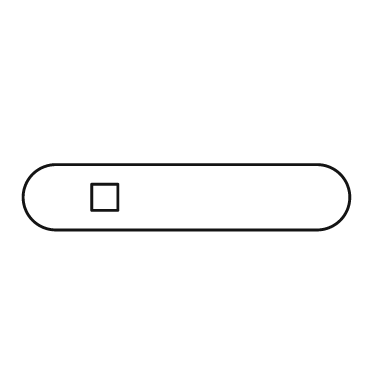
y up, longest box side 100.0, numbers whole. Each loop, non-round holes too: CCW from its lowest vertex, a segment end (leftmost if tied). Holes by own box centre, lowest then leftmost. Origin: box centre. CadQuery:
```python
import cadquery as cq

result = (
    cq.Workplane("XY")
    .moveTo(-40.0, -10.0)
    .lineTo(40.0, -10.0)
    .threePointArc((50.0, 0.0), (40.0, 10.0))
    .lineTo(-40.0, 10.0)
    .threePointArc((-50.0, 0.0), (-40.0, -10.0))
    .close()
    .moveTo(-29.0, -4.0)
    .lineTo(-21.0, -4.0)
    .lineTo(-21.0, 4.0)
    .lineTo(-29.0, 4.0)
    .close()
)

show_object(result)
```